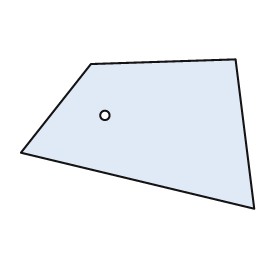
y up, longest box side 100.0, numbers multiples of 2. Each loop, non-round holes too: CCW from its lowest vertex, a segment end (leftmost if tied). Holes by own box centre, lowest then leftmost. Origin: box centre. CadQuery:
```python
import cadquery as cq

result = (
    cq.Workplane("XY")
    .moveTo(50.0, -32.0)
    .lineTo(42.0, 32.0)
    .lineTo(-20.0, 30.0)
    .lineTo(-50.0, -8.0)
    .close()
    .moveTo(-14.0, 8.0)
    .circle(2.0)
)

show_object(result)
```